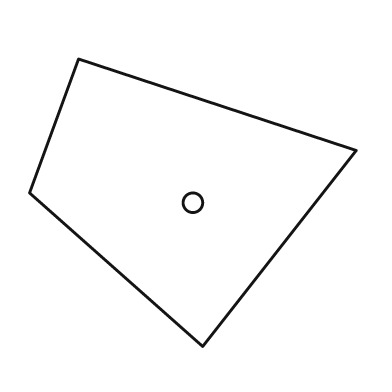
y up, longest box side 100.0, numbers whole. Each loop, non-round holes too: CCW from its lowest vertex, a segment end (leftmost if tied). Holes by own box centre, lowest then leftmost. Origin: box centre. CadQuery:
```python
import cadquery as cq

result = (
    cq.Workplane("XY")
    .moveTo(3.0, -44.0)
    .lineTo(50.0, 16.0)
    .lineTo(-35.0, 44.0)
    .lineTo(-50.0, 3.0)
    .close()
    .moveTo(0.0, 0.0)
    .circle(3.0)
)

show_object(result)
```